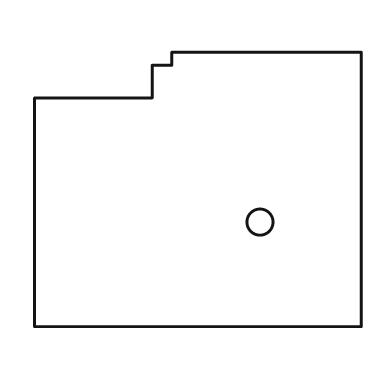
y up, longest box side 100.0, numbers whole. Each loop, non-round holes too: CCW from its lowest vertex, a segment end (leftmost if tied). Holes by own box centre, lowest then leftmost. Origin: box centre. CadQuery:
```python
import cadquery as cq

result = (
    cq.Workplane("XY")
    .moveTo(-50.0, -42.0)
    .lineTo(50.0, -42.0)
    .lineTo(50.0, 42.0)
    .lineTo(-8.0, 42.0)
    .lineTo(-8.0, 38.0)
    .lineTo(-14.0, 38.0)
    .lineTo(-14.0, 28.0)
    .lineTo(-50.0, 28.0)
    .close()
    .moveTo(19.0, -10.0)
    .circle(4.0)
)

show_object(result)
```